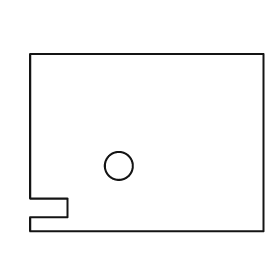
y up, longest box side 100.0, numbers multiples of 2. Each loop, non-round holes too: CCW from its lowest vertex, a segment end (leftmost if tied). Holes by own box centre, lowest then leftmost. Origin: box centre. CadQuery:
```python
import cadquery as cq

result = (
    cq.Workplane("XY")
    .moveTo(-50.0, -38.0)
    .lineTo(50.0, -38.0)
    .lineTo(50.0, 38.0)
    .lineTo(-50.0, 38.0)
    .lineTo(-50.0, -24.0)
    .lineTo(-34.0, -24.0)
    .lineTo(-34.0, -32.0)
    .lineTo(-50.0, -32.0)
    .close()
    .moveTo(-12.0, -10.0)
    .circle(6.0)
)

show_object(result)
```